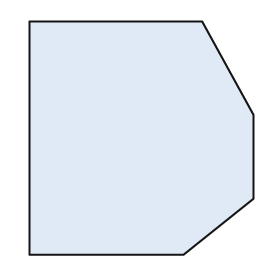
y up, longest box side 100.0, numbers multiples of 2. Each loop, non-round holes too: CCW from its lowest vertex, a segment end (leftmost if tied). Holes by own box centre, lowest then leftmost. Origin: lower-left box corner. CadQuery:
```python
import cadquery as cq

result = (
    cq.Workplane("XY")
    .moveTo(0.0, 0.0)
    .lineTo(66.0, 0.0)
    .lineTo(96.0, 24.0)
    .lineTo(96.0, 60.0)
    .lineTo(74.0, 100.0)
    .lineTo(0.0, 100.0)
    .close()
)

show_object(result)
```